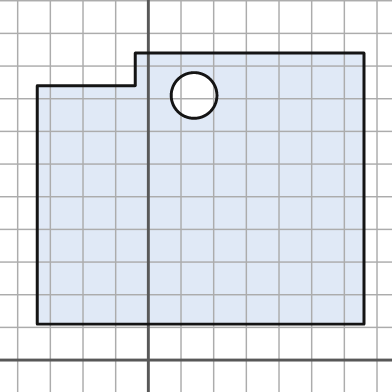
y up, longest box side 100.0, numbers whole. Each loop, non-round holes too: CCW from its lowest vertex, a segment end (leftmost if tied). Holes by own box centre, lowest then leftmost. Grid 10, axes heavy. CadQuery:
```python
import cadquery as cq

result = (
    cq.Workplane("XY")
    .moveTo(-34.0, 11.0)
    .lineTo(66.0, 11.0)
    .lineTo(66.0, 94.0)
    .lineTo(-4.0, 94.0)
    .lineTo(-4.0, 84.0)
    .lineTo(-34.0, 84.0)
    .close()
    .moveTo(14.0, 81.0)
    .circle(7.0)
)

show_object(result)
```